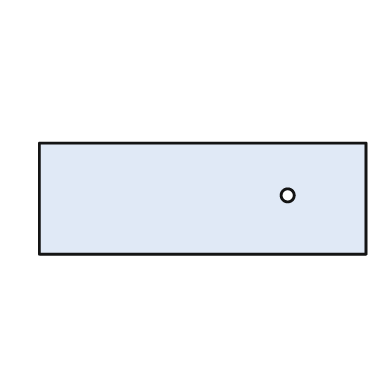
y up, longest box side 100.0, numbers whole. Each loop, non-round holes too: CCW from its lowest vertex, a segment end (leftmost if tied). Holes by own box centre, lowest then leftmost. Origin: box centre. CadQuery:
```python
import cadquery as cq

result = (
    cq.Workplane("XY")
    .moveTo(-50.0, -17.0)
    .lineTo(50.0, -17.0)
    .lineTo(50.0, 17.0)
    .lineTo(-50.0, 17.0)
    .close()
    .moveTo(26.0, 1.0)
    .circle(2.0)
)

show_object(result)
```